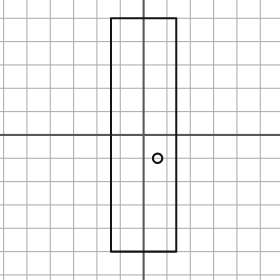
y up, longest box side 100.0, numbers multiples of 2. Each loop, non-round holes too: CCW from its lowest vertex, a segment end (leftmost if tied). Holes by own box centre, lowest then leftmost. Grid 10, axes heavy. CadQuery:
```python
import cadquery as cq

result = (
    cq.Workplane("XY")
    .moveTo(-14.0, -50.0)
    .lineTo(14.0, -50.0)
    .lineTo(14.0, 50.0)
    .lineTo(-14.0, 50.0)
    .close()
    .moveTo(6.0, -10.0)
    .circle(2.0)
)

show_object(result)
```